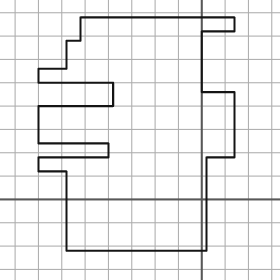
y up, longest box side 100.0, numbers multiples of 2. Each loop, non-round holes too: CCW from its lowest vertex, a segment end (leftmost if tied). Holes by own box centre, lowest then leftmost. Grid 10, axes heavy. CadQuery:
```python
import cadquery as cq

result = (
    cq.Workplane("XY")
    .moveTo(-58.0, -22.0)
    .lineTo(2.0, -22.0)
    .lineTo(2.0, 18.0)
    .lineTo(14.0, 18.0)
    .lineTo(14.0, 46.0)
    .lineTo(0.0, 46.0)
    .lineTo(0.0, 72.0)
    .lineTo(14.0, 72.0)
    .lineTo(14.0, 78.0)
    .lineTo(-52.0, 78.0)
    .lineTo(-52.0, 68.0)
    .lineTo(-58.0, 68.0)
    .lineTo(-58.0, 56.0)
    .lineTo(-70.0, 56.0)
    .lineTo(-70.0, 50.0)
    .lineTo(-38.0, 50.0)
    .lineTo(-38.0, 40.0)
    .lineTo(-70.0, 40.0)
    .lineTo(-70.0, 24.0)
    .lineTo(-40.0, 24.0)
    .lineTo(-40.0, 18.0)
    .lineTo(-70.0, 18.0)
    .lineTo(-70.0, 12.0)
    .lineTo(-58.0, 12.0)
    .close()
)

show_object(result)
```